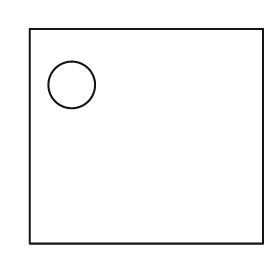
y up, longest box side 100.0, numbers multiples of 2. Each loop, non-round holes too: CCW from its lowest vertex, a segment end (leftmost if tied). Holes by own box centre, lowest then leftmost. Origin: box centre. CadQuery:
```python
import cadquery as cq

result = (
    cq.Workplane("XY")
    .moveTo(-50.0, -46.0)
    .lineTo(50.0, -46.0)
    .lineTo(50.0, 46.0)
    .lineTo(-50.0, 46.0)
    .close()
    .moveTo(-32.0, 22.0)
    .circle(10.0)
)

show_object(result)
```